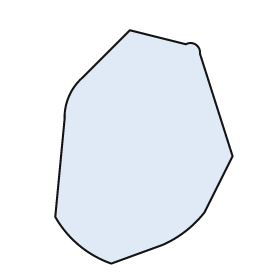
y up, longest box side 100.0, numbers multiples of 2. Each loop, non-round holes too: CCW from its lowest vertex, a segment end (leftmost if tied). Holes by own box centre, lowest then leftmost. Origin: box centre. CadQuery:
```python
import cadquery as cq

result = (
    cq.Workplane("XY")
    .moveTo(-14.0, -50.0)
    .lineTo(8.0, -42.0)
    .threePointArc((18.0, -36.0), (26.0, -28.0))
    .lineTo(38.0, -4.0)
    .lineTo(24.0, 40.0)
    .threePointArc((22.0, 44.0), (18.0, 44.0))
    .lineTo(-6.0, 50.0)
    .lineTo(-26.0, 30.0)
    .threePointArc((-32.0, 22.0), (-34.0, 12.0))
    .lineTo(-38.0, -30.0)
    .threePointArc((-28.0, -42.0), (-14.0, -50.0))
    .close()
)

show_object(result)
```